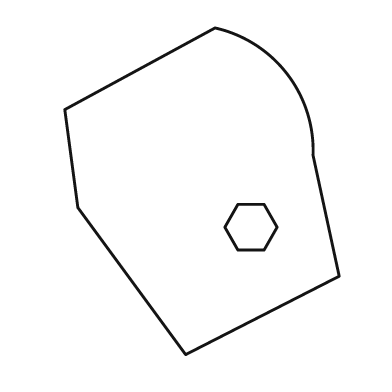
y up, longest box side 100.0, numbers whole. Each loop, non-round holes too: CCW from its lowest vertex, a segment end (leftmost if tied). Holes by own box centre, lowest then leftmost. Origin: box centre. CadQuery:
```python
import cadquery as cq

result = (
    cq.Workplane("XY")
    .moveTo(-5.0, -50.0)
    .lineTo(42.0, -26.0)
    .lineTo(34.0, 11.0)
    .threePointArc((26.0, 36.0), (4.0, 50.0))
    .lineTo(-42.0, 25.0)
    .lineTo(-38.0, -5.0)
    .close()
    .moveTo(11.0, -18.0)
    .lineTo(19.0, -18.0)
    .lineTo(23.0, -11.0)
    .lineTo(19.0, -4.0)
    .lineTo(11.0, -4.0)
    .lineTo(7.0, -11.0)
    .close()
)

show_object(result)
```